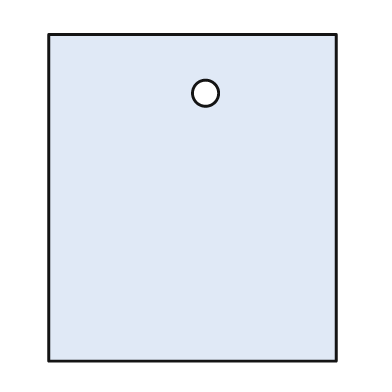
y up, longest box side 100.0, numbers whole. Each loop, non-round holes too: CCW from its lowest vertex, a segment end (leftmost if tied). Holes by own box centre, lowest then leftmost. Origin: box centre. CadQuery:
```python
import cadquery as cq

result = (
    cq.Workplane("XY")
    .moveTo(-44.0, -50.0)
    .lineTo(44.0, -50.0)
    .lineTo(44.0, 50.0)
    .lineTo(-44.0, 50.0)
    .close()
    .moveTo(4.0, 32.0)
    .circle(4.0)
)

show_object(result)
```